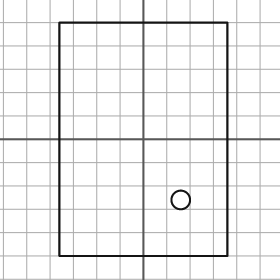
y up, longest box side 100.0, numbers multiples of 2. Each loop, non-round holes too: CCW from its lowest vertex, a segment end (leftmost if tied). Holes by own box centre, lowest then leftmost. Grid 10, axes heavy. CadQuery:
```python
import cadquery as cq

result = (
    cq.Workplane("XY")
    .moveTo(-36.0, -50.0)
    .lineTo(36.0, -50.0)
    .lineTo(36.0, 50.0)
    .lineTo(-36.0, 50.0)
    .close()
    .moveTo(16.0, -26.0)
    .circle(4.0)
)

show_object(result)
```